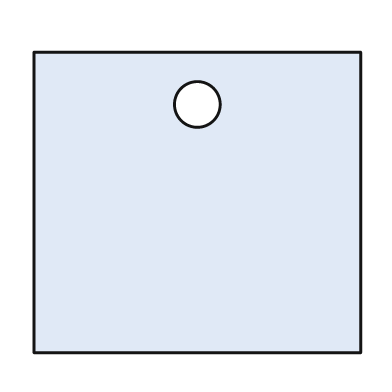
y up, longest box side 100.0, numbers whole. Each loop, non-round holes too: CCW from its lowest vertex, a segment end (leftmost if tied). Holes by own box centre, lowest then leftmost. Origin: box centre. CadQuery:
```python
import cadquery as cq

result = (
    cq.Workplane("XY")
    .moveTo(-50.0, -46.0)
    .lineTo(50.0, -46.0)
    .lineTo(50.0, 46.0)
    .lineTo(-50.0, 46.0)
    .close()
    .moveTo(0.0, 30.0)
    .circle(7.0)
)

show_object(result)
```